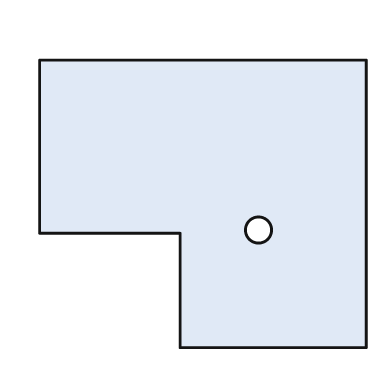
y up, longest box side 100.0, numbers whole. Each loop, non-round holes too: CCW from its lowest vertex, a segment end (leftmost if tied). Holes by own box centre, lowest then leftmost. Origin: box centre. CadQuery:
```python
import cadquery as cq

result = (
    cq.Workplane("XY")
    .moveTo(-7.0, -44.0)
    .lineTo(50.0, -44.0)
    .lineTo(50.0, 44.0)
    .lineTo(-50.0, 44.0)
    .lineTo(-50.0, -9.0)
    .lineTo(-7.0, -9.0)
    .close()
    .moveTo(17.0, -8.0)
    .circle(4.0)
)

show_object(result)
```